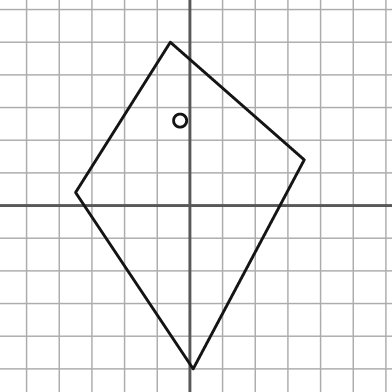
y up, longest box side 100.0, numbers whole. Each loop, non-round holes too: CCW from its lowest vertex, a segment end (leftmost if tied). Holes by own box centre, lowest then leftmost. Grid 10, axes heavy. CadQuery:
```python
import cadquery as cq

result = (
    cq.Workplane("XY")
    .moveTo(1.0, -50.0)
    .lineTo(35.0, 14.0)
    .lineTo(-6.0, 50.0)
    .lineTo(-35.0, 4.0)
    .close()
    .moveTo(-3.0, 26.0)
    .circle(2.0)
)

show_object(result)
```